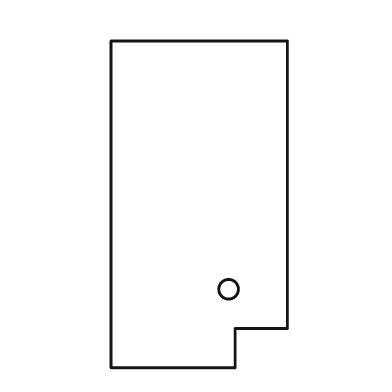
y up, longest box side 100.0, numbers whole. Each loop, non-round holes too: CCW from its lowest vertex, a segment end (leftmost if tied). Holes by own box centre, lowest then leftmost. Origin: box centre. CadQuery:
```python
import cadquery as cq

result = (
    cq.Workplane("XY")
    .moveTo(-27.0, -50.0)
    .lineTo(11.0, -50.0)
    .lineTo(11.0, -38.0)
    .lineTo(27.0, -38.0)
    .lineTo(27.0, 50.0)
    .lineTo(-27.0, 50.0)
    .close()
    .moveTo(9.0, -26.0)
    .circle(3.0)
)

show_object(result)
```